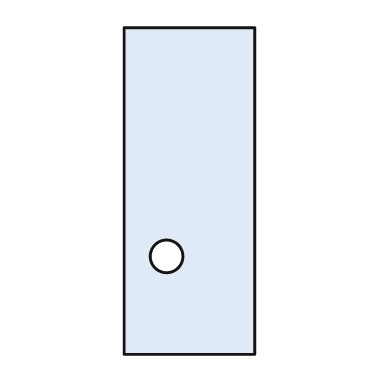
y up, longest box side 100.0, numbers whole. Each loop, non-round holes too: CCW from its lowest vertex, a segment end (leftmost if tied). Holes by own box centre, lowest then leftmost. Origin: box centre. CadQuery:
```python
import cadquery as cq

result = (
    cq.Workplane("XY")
    .moveTo(-20.0, -50.0)
    .lineTo(20.0, -50.0)
    .lineTo(20.0, 50.0)
    .lineTo(-20.0, 50.0)
    .close()
    .moveTo(-7.0, -20.0)
    .circle(5.0)
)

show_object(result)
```